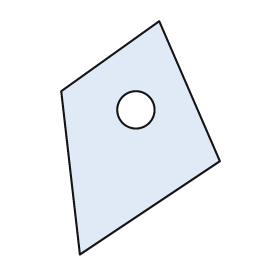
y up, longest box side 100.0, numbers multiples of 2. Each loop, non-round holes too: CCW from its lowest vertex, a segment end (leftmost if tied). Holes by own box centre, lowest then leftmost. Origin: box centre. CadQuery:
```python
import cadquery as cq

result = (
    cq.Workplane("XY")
    .moveTo(-26.0, -50.0)
    .lineTo(34.0, -10.0)
    .lineTo(8.0, 50.0)
    .lineTo(-34.0, 20.0)
    .close()
    .moveTo(-2.0, 12.0)
    .circle(8.0)
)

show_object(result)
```